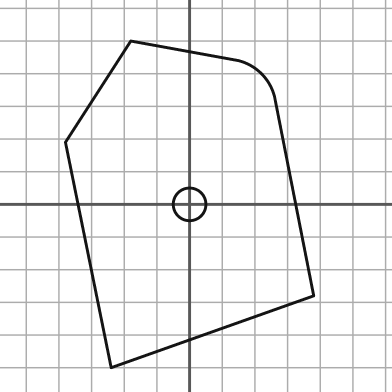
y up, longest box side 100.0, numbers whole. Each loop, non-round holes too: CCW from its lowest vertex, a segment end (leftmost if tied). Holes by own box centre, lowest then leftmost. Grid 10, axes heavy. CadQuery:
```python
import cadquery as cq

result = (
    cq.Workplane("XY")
    .moveTo(-24.0, -50.0)
    .lineTo(38.0, -28.0)
    .lineTo(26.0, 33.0)
    .threePointArc((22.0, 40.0), (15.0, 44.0))
    .lineTo(-18.0, 50.0)
    .lineTo(-38.0, 19.0)
    .close()
    .moveTo(0.0, 0.0)
    .circle(5.0)
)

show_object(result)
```